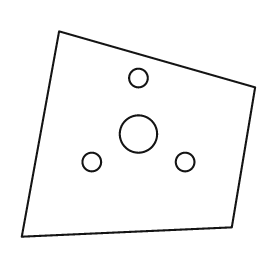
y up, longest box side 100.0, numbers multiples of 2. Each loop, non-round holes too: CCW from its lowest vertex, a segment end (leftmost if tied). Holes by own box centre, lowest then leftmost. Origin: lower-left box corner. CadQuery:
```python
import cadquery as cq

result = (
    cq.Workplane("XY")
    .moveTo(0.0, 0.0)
    .lineTo(90.0, 4.0)
    .lineTo(100.0, 64.0)
    .lineTo(16.0, 88.0)
    .close()
    .moveTo(30.0, 32.0)
    .circle(4.0)
    .moveTo(70.0, 32.0)
    .circle(4.0)
    .moveTo(50.0, 44.0)
    .circle(8.0)
    .moveTo(50.0, 68.0)
    .circle(4.0)
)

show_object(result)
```